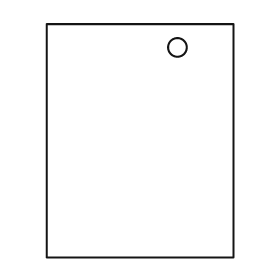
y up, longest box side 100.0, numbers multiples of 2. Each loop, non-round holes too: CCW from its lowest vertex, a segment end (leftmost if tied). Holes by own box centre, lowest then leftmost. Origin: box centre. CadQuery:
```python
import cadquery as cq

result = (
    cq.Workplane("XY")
    .moveTo(-40.0, -50.0)
    .lineTo(40.0, -50.0)
    .lineTo(40.0, 50.0)
    .lineTo(-40.0, 50.0)
    .close()
    .moveTo(16.0, 40.0)
    .circle(4.0)
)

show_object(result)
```